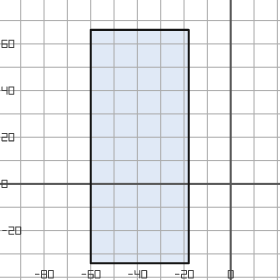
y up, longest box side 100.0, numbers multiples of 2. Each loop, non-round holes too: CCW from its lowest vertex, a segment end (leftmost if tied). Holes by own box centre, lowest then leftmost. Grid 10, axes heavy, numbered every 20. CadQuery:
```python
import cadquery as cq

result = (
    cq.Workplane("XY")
    .moveTo(-60.0, -34.0)
    .lineTo(-18.0, -34.0)
    .lineTo(-18.0, 66.0)
    .lineTo(-60.0, 66.0)
    .close()
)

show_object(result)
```